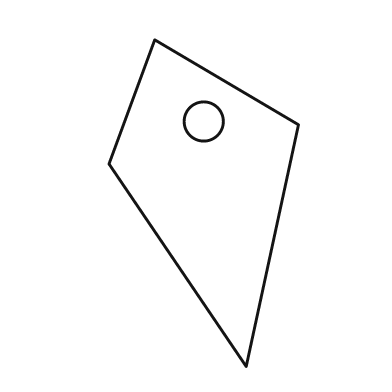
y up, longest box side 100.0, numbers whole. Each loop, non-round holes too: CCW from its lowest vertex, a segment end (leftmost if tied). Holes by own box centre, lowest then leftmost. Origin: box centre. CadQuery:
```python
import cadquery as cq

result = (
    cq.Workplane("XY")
    .moveTo(13.0, -50.0)
    .lineTo(29.0, 24.0)
    .lineTo(-15.0, 50.0)
    .lineTo(-29.0, 12.0)
    .close()
    .moveTo(0.0, 25.0)
    .circle(6.0)
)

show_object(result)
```